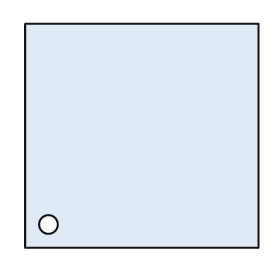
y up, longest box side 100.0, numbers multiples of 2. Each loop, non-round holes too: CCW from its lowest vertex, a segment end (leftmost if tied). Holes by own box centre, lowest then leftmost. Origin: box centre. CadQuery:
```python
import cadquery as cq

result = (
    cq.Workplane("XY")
    .moveTo(-50.0, -48.0)
    .lineTo(50.0, -48.0)
    .lineTo(50.0, 48.0)
    .lineTo(-50.0, 48.0)
    .close()
    .moveTo(-40.0, -38.0)
    .circle(4.0)
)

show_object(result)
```